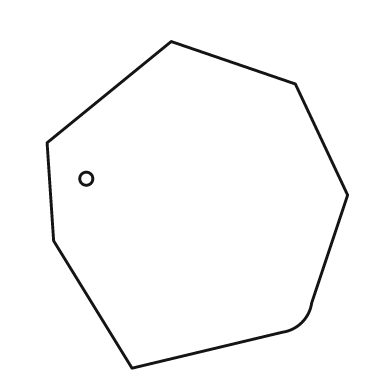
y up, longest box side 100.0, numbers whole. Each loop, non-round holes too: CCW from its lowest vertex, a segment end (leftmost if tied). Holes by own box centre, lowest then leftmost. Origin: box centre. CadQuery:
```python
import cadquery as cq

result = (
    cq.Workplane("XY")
    .moveTo(-20.0, -50.0)
    .lineTo(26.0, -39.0)
    .threePointArc((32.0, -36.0), (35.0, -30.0))
    .lineTo(46.0, 3.0)
    .lineTo(30.0, 37.0)
    .lineTo(-8.0, 50.0)
    .lineTo(-46.0, 19.0)
    .lineTo(-44.0, -11.0)
    .close()
    .moveTo(-34.0, 8.0)
    .circle(2.0)
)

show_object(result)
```